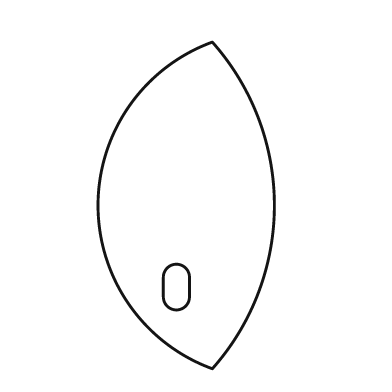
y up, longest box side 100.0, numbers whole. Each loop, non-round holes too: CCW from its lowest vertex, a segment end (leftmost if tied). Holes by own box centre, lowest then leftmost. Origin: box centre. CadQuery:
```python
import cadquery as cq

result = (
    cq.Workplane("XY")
    .moveTo(8.0, -50.0)
    .threePointArc((27.0, 0.0), (8.0, 50.0))
    .threePointArc((-27.0, 0.0), (8.0, -50.0))
    .close()
    .moveTo(-7.0, -28.0)
    .threePointArc((-3.0, -32.0), (1.0, -28.0))
    .lineTo(1.0, -22.0)
    .threePointArc((-3.0, -18.0), (-7.0, -22.0))
    .close()
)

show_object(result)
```